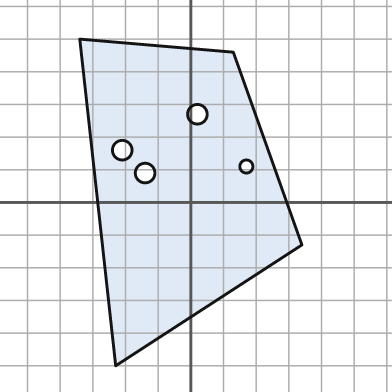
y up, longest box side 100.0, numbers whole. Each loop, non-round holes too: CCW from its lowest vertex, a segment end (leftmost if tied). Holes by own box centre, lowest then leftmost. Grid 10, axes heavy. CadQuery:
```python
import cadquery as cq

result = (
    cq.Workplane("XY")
    .moveTo(-23.0, -50.0)
    .lineTo(34.0, -13.0)
    .lineTo(13.0, 46.0)
    .lineTo(-34.0, 50.0)
    .close()
    .moveTo(-14.0, 9.0)
    .circle(3.0)
    .moveTo(17.0, 11.0)
    .circle(2.0)
    .moveTo(-21.0, 16.0)
    .circle(3.0)
    .moveTo(2.0, 27.0)
    .circle(3.0)
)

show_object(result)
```